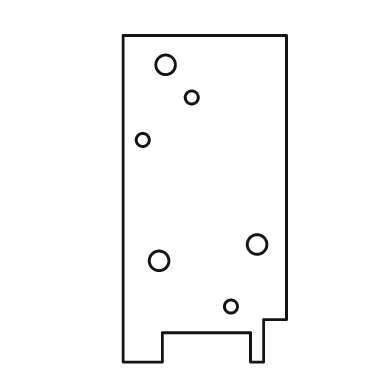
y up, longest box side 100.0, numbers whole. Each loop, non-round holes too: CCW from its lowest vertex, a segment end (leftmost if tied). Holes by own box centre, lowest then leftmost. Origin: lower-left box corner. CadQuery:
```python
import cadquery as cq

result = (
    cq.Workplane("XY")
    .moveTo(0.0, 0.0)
    .lineTo(12.0, 0.0)
    .lineTo(12.0, 9.0)
    .lineTo(39.0, 9.0)
    .lineTo(39.0, 0.0)
    .lineTo(43.0, 0.0)
    .lineTo(43.0, 13.0)
    .lineTo(50.0, 13.0)
    .lineTo(50.0, 100.0)
    .lineTo(0.0, 100.0)
    .close()
    .moveTo(33.0, 17.0)
    .circle(2.0)
    .moveTo(11.0, 31.0)
    .circle(3.0)
    .moveTo(41.0, 36.0)
    .circle(3.0)
    .moveTo(6.0, 68.0)
    .circle(2.0)
    .moveTo(21.0, 81.0)
    .circle(2.0)
    .moveTo(13.0, 91.0)
    .circle(3.0)
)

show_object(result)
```